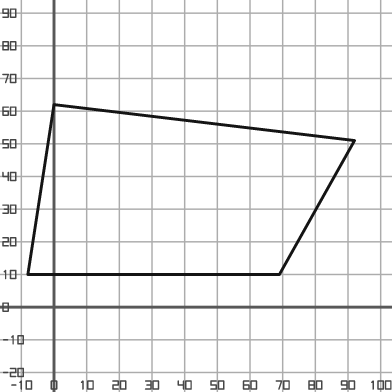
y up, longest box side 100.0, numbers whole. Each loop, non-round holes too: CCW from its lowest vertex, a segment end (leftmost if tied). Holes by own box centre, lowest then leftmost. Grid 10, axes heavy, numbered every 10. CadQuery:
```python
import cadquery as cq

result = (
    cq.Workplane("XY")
    .moveTo(-8.0, 10.0)
    .lineTo(69.0, 10.0)
    .lineTo(92.0, 51.0)
    .lineTo(0.0, 62.0)
    .close()
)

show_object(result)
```